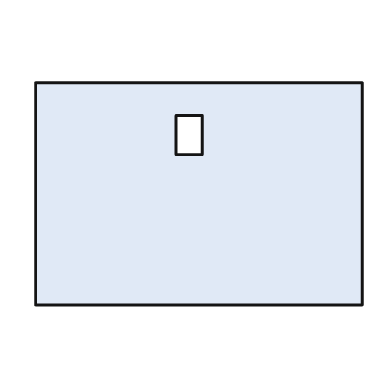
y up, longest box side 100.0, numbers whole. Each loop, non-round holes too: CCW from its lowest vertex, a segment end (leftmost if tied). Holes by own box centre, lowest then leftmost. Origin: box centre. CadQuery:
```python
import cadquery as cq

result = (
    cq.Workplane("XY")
    .moveTo(-50.0, -34.0)
    .lineTo(50.0, -34.0)
    .lineTo(50.0, 34.0)
    .lineTo(-50.0, 34.0)
    .close()
    .moveTo(-7.0, 12.0)
    .lineTo(1.0, 12.0)
    .lineTo(1.0, 24.0)
    .lineTo(-7.0, 24.0)
    .close()
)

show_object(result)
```